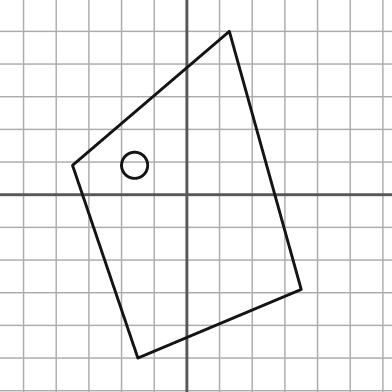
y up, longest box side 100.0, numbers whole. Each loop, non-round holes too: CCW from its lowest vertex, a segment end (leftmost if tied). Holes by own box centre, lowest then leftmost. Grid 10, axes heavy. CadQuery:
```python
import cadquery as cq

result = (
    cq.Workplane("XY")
    .moveTo(-15.0, -50.0)
    .lineTo(35.0, -29.0)
    .lineTo(13.0, 50.0)
    .lineTo(-35.0, 9.0)
    .close()
    .moveTo(-16.0, 9.0)
    .circle(4.0)
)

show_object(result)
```